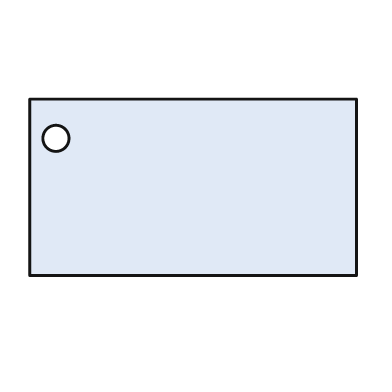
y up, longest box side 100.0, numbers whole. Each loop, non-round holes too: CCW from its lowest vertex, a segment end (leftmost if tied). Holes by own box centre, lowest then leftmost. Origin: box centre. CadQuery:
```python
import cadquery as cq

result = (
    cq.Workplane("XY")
    .moveTo(-50.0, -27.0)
    .lineTo(50.0, -27.0)
    .lineTo(50.0, 27.0)
    .lineTo(-50.0, 27.0)
    .close()
    .moveTo(-42.0, 15.0)
    .circle(4.0)
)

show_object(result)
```